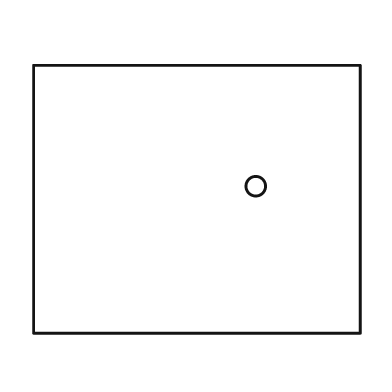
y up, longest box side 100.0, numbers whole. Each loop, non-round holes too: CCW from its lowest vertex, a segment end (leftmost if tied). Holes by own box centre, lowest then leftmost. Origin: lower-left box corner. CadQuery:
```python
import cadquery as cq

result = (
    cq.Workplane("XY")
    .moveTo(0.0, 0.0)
    .lineTo(100.0, 0.0)
    .lineTo(100.0, 82.0)
    .lineTo(0.0, 82.0)
    .close()
    .moveTo(68.0, 45.0)
    .circle(3.0)
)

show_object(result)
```